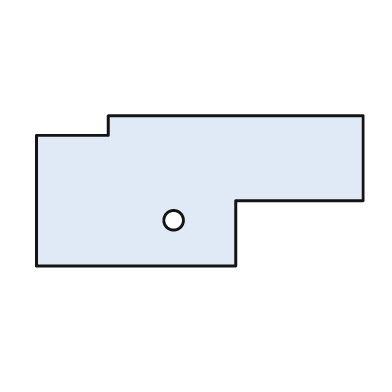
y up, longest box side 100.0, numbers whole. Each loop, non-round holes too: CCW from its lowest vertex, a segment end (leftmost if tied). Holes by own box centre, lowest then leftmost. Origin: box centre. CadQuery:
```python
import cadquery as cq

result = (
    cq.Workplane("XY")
    .moveTo(-50.0, -23.0)
    .lineTo(11.0, -23.0)
    .lineTo(11.0, -3.0)
    .lineTo(50.0, -3.0)
    .lineTo(50.0, 23.0)
    .lineTo(-28.0, 23.0)
    .lineTo(-28.0, 17.0)
    .lineTo(-50.0, 17.0)
    .close()
    .moveTo(-8.0, -9.0)
    .circle(3.0)
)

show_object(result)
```